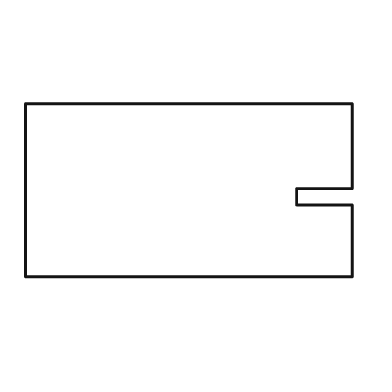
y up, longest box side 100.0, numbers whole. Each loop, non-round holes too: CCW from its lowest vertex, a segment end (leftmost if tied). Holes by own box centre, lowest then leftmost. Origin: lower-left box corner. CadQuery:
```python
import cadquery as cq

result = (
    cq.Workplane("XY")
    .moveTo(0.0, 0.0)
    .lineTo(100.0, 0.0)
    .lineTo(100.0, 22.0)
    .lineTo(83.0, 22.0)
    .lineTo(83.0, 27.0)
    .lineTo(100.0, 27.0)
    .lineTo(100.0, 53.0)
    .lineTo(0.0, 53.0)
    .close()
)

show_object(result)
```